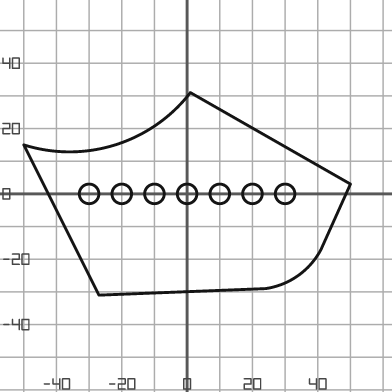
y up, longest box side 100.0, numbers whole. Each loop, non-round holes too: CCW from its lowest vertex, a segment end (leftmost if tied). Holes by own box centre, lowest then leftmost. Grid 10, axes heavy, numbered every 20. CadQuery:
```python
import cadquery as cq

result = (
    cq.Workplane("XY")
    .moveTo(-27.0, -31.0)
    .lineTo(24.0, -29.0)
    .threePointArc((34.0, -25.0), (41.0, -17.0))
    .lineTo(50.0, 3.0)
    .lineTo(1.0, 31.0)
    .threePointArc((-22.0, 15.0), (-50.0, 15.0))
    .close()
    .moveTo(-30.0, 0.0)
    .circle(3.0)
    .moveTo(-20.0, 0.0)
    .circle(3.0)
    .moveTo(-10.0, 0.0)
    .circle(3.0)
    .moveTo(0.0, 0.0)
    .circle(3.0)
    .moveTo(10.0, 0.0)
    .circle(3.0)
    .moveTo(20.0, 0.0)
    .circle(3.0)
    .moveTo(30.0, 0.0)
    .circle(3.0)
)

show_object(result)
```